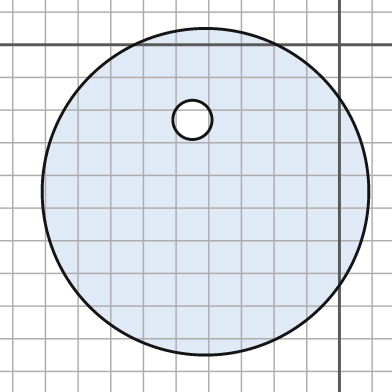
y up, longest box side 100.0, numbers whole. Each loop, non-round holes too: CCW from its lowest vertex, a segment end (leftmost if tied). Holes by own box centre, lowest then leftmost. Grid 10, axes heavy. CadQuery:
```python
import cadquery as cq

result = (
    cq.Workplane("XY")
    .moveTo(-41.0, -45.0)
    .circle(50.0)
    .moveTo(-45.0, -23.0)
    .circle(6.0)
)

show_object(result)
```